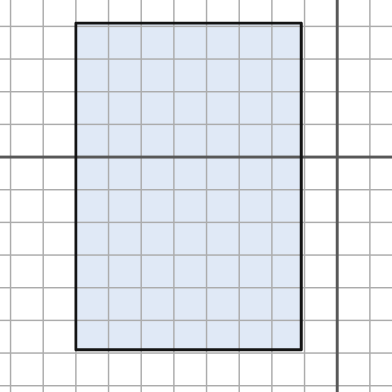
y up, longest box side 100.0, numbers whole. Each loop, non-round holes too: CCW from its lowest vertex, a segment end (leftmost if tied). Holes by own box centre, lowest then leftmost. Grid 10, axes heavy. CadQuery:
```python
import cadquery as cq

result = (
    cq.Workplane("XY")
    .moveTo(-80.0, -59.0)
    .lineTo(-11.0, -59.0)
    .lineTo(-11.0, 41.0)
    .lineTo(-80.0, 41.0)
    .close()
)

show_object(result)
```